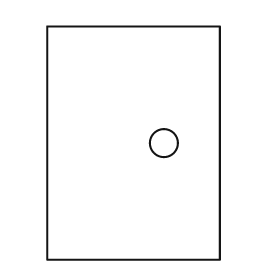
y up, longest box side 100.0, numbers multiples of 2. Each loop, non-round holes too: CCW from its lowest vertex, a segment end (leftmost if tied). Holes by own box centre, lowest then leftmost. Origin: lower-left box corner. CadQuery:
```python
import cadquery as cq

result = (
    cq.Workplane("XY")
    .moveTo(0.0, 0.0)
    .lineTo(74.0, 0.0)
    .lineTo(74.0, 100.0)
    .lineTo(0.0, 100.0)
    .close()
    .moveTo(50.0, 50.0)
    .circle(6.0)
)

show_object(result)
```